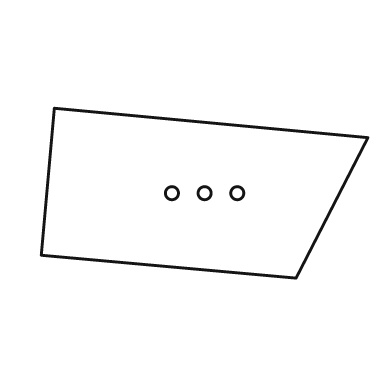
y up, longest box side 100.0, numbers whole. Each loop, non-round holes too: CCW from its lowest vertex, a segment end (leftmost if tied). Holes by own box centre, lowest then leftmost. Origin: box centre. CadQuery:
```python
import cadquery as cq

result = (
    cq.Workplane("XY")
    .moveTo(28.0, -26.0)
    .lineTo(50.0, 17.0)
    .lineTo(-46.0, 26.0)
    .lineTo(-50.0, -19.0)
    .close()
    .moveTo(-10.0, 0.0)
    .circle(2.0)
    .moveTo(0.0, 0.0)
    .circle(2.0)
    .moveTo(10.0, 0.0)
    .circle(2.0)
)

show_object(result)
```